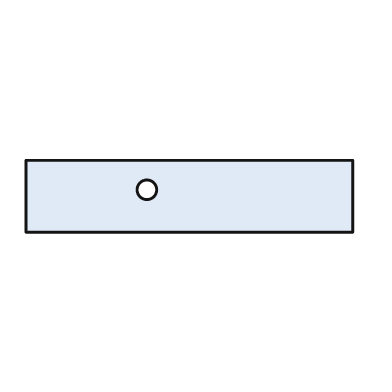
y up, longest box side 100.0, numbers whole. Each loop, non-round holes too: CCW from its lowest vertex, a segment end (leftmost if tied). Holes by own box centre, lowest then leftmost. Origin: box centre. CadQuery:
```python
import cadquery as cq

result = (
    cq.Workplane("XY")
    .moveTo(-50.0, -11.0)
    .lineTo(50.0, -11.0)
    .lineTo(50.0, 11.0)
    .lineTo(-50.0, 11.0)
    .close()
    .moveTo(-13.0, 2.0)
    .circle(3.0)
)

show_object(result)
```